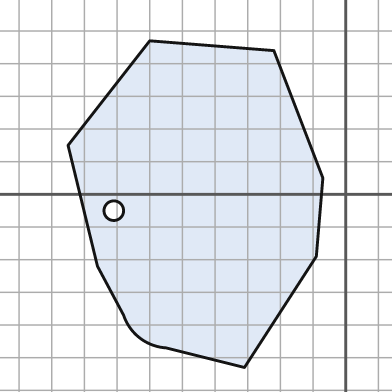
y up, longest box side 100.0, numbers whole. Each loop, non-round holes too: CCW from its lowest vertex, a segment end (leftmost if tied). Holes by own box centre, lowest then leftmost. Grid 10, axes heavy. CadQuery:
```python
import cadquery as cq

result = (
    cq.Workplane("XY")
    .moveTo(-31.0, -53.0)
    .lineTo(-9.0, -19.0)
    .lineTo(-7.0, 5.0)
    .lineTo(-22.0, 44.0)
    .lineTo(-60.0, 47.0)
    .lineTo(-85.0, 15.0)
    .lineTo(-76.0, -22.0)
    .lineTo(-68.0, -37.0)
    .threePointArc((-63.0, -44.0), (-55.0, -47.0))
    .close()
    .moveTo(-71.0, -5.0)
    .circle(3.0)
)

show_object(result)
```